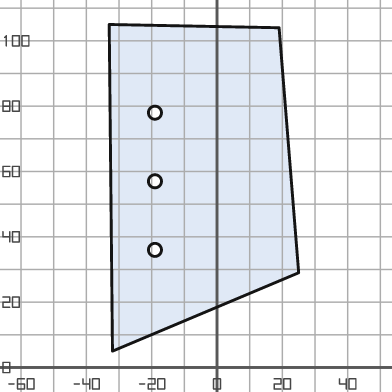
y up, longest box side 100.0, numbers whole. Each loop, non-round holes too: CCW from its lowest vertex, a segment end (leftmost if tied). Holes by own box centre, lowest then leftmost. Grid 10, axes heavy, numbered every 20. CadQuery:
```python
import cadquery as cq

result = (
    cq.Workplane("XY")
    .moveTo(-32.0, 5.0)
    .lineTo(25.0, 29.0)
    .lineTo(19.0, 104.0)
    .lineTo(-33.0, 105.0)
    .close()
    .moveTo(-19.0, 36.0)
    .circle(2.0)
    .moveTo(-19.0, 57.0)
    .circle(2.0)
    .moveTo(-19.0, 78.0)
    .circle(2.0)
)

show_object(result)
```